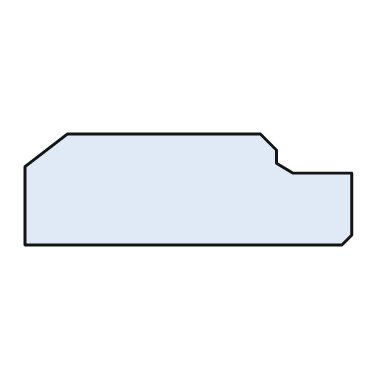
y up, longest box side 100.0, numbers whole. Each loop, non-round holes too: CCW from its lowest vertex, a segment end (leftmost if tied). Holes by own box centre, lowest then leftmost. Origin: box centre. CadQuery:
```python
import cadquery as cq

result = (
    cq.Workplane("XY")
    .moveTo(-50.0, -17.0)
    .lineTo(47.0, -17.0)
    .lineTo(50.0, -14.0)
    .lineTo(50.0, 5.0)
    .lineTo(32.0, 5.0)
    .lineTo(27.0, 8.0)
    .lineTo(27.0, 12.0)
    .lineTo(22.0, 17.0)
    .lineTo(-37.0, 17.0)
    .lineTo(-50.0, 7.0)
    .close()
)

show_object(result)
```